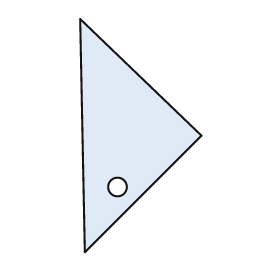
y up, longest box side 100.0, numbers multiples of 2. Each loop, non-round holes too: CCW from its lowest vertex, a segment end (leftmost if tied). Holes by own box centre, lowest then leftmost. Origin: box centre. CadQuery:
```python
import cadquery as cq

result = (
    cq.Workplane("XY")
    .moveTo(-24.0, -50.0)
    .lineTo(26.0, 0.0)
    .lineTo(-26.0, 50.0)
    .close()
    .moveTo(-10.0, -22.0)
    .circle(4.0)
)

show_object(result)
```